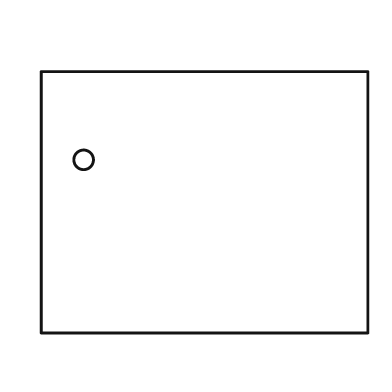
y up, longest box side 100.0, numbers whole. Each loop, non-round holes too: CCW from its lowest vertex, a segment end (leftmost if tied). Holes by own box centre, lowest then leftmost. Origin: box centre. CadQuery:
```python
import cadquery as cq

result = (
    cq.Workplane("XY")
    .moveTo(-50.0, -40.0)
    .lineTo(50.0, -40.0)
    .lineTo(50.0, 40.0)
    .lineTo(-50.0, 40.0)
    .close()
    .moveTo(-37.0, 13.0)
    .circle(3.0)
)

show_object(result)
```